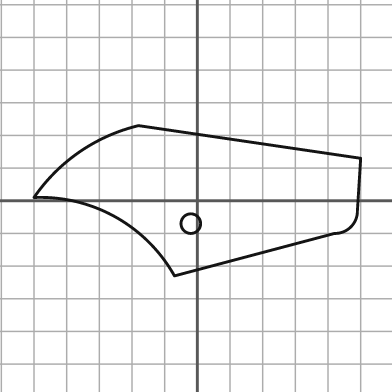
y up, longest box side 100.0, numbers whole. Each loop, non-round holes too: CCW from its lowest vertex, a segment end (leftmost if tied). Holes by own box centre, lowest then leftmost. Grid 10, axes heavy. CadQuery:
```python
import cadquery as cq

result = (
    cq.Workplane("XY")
    .moveTo(-7.0, -23.0)
    .lineTo(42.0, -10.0)
    .threePointArc((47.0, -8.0), (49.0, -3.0))
    .lineTo(50.0, 13.0)
    .lineTo(-18.0, 23.0)
    .threePointArc((-36.0, 15.0), (-50.0, 1.0))
    .threePointArc((-25.0, -5.0), (-7.0, -23.0))
    .close()
    .moveTo(-2.0, -7.0)
    .circle(3.0)
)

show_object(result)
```